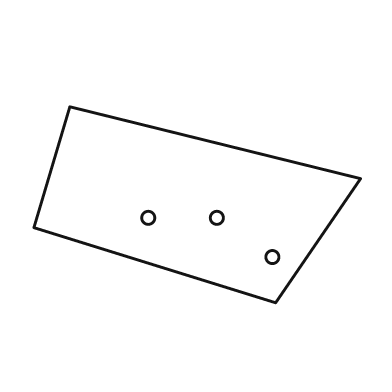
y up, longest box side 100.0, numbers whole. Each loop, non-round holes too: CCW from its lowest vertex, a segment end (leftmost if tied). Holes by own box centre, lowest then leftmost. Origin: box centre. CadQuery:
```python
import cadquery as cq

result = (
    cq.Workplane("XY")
    .moveTo(24.0, -30.0)
    .lineTo(50.0, 8.0)
    .lineTo(-39.0, 30.0)
    .lineTo(-50.0, -7.0)
    .close()
    .moveTo(23.0, -16.0)
    .circle(2.0)
    .moveTo(-15.0, -4.0)
    .circle(2.0)
    .moveTo(6.0, -4.0)
    .circle(2.0)
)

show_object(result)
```